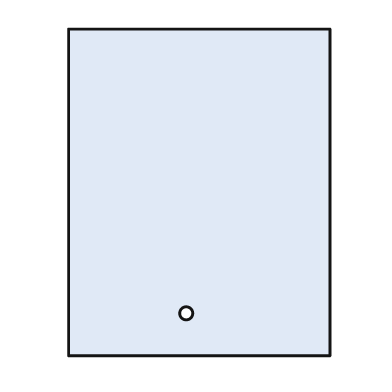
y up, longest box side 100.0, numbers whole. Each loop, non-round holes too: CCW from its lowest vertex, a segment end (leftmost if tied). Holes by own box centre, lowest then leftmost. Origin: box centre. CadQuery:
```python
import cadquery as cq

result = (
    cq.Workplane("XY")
    .moveTo(-40.0, -50.0)
    .lineTo(40.0, -50.0)
    .lineTo(40.0, 50.0)
    .lineTo(-40.0, 50.0)
    .close()
    .moveTo(-4.0, -37.0)
    .circle(2.0)
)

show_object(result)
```